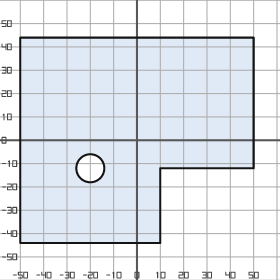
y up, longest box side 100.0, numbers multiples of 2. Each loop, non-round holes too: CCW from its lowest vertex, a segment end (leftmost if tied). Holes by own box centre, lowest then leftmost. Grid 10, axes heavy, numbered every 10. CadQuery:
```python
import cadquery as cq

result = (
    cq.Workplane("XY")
    .moveTo(-50.0, -44.0)
    .lineTo(10.0, -44.0)
    .lineTo(10.0, -12.0)
    .lineTo(50.0, -12.0)
    .lineTo(50.0, 44.0)
    .lineTo(-50.0, 44.0)
    .close()
    .moveTo(-20.0, -12.0)
    .circle(6.0)
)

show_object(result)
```